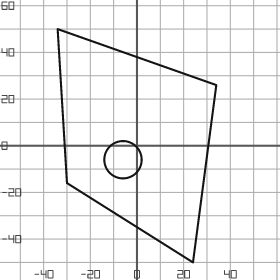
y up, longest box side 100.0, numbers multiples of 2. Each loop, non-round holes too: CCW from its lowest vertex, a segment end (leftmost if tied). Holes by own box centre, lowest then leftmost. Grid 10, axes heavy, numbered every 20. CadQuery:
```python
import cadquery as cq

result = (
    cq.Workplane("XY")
    .moveTo(24.0, -50.0)
    .lineTo(34.0, 26.0)
    .lineTo(-34.0, 50.0)
    .lineTo(-30.0, -16.0)
    .close()
    .moveTo(-6.0, -6.0)
    .circle(8.0)
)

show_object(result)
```